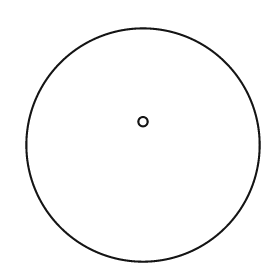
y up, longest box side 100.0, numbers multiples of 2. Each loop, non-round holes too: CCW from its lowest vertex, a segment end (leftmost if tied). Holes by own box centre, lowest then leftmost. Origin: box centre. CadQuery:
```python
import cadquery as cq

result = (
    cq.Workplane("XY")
    .moveTo(0.0, 0.0)
    .circle(50.0)
    .moveTo(0.0, 10.0)
    .circle(2.0)
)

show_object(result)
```